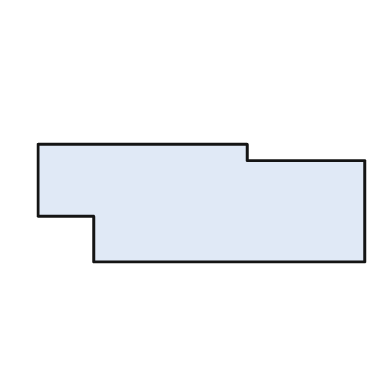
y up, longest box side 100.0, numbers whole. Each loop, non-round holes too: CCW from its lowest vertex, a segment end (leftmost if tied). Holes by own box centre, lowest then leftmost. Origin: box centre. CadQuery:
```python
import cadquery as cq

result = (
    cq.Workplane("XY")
    .moveTo(-33.0, -18.0)
    .lineTo(50.0, -18.0)
    .lineTo(50.0, 13.0)
    .lineTo(14.0, 13.0)
    .lineTo(14.0, 18.0)
    .lineTo(-50.0, 18.0)
    .lineTo(-50.0, -4.0)
    .lineTo(-33.0, -4.0)
    .close()
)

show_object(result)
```